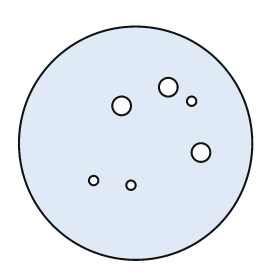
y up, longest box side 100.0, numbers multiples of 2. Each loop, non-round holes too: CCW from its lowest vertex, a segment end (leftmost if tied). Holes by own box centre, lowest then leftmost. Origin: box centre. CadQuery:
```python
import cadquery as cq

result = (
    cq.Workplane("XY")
    .moveTo(0.0, 0.0)
    .circle(50.0)
    .moveTo(-2.0, -18.0)
    .circle(2.0)
    .moveTo(-18.0, -16.0)
    .circle(2.0)
    .moveTo(28.0, -4.0)
    .circle(4.0)
    .moveTo(-6.0, 16.0)
    .circle(4.0)
    .moveTo(24.0, 18.0)
    .circle(2.0)
    .moveTo(14.0, 24.0)
    .circle(4.0)
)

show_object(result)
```